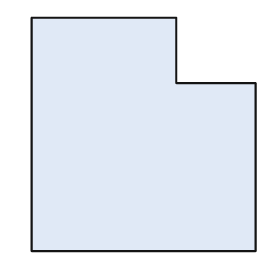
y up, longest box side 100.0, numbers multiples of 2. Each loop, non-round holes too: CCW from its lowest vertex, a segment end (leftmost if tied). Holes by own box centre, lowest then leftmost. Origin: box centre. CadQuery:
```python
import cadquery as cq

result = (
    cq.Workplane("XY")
    .moveTo(-48.0, -50.0)
    .lineTo(48.0, -50.0)
    .lineTo(48.0, 22.0)
    .lineTo(14.0, 22.0)
    .lineTo(14.0, 50.0)
    .lineTo(-48.0, 50.0)
    .close()
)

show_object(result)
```